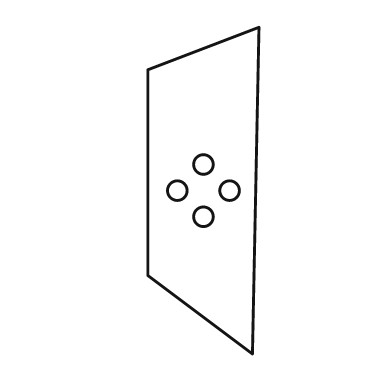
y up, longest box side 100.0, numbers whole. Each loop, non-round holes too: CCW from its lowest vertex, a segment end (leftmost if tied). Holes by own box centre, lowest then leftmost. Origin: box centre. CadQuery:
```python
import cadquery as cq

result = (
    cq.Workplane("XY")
    .moveTo(15.0, -50.0)
    .lineTo(17.0, 50.0)
    .lineTo(-17.0, 37.0)
    .lineTo(-17.0, -26.0)
    .close()
    .moveTo(0.0, -8.0)
    .circle(3.0)
    .moveTo(-8.0, 0.0)
    .circle(3.0)
    .moveTo(8.0, 0.0)
    .circle(3.0)
    .moveTo(0.0, 8.0)
    .circle(3.0)
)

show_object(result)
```